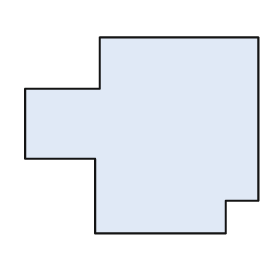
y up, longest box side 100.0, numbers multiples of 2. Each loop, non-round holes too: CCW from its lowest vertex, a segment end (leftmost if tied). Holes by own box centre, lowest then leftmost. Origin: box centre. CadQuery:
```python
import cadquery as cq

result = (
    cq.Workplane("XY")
    .moveTo(-20.0, -42.0)
    .lineTo(36.0, -42.0)
    .lineTo(36.0, -28.0)
    .lineTo(50.0, -28.0)
    .lineTo(50.0, 42.0)
    .lineTo(-18.0, 42.0)
    .lineTo(-18.0, 20.0)
    .lineTo(-50.0, 20.0)
    .lineTo(-50.0, -10.0)
    .lineTo(-20.0, -10.0)
    .close()
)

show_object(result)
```